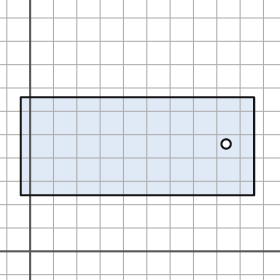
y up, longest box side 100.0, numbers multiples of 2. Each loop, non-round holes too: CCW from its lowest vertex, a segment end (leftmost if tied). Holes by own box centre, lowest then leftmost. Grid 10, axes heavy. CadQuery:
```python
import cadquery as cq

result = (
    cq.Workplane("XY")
    .moveTo(-4.0, 24.0)
    .lineTo(96.0, 24.0)
    .lineTo(96.0, 66.0)
    .lineTo(-4.0, 66.0)
    .close()
    .moveTo(84.0, 46.0)
    .circle(2.0)
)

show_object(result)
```